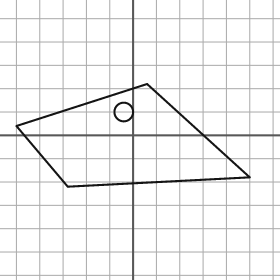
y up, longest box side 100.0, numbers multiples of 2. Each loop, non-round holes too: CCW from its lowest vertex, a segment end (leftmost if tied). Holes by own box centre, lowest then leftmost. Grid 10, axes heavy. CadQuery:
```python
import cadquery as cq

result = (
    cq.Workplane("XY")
    .moveTo(-28.0, -22.0)
    .lineTo(50.0, -18.0)
    .lineTo(6.0, 22.0)
    .lineTo(-50.0, 4.0)
    .close()
    .moveTo(-4.0, 10.0)
    .circle(4.0)
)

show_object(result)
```